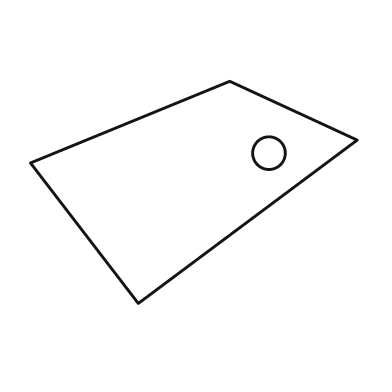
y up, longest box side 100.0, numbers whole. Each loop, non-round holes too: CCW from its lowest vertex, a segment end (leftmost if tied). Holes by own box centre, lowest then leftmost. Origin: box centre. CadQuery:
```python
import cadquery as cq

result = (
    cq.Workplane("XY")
    .moveTo(-17.0, -34.0)
    .lineTo(50.0, 16.0)
    .lineTo(11.0, 34.0)
    .lineTo(-50.0, 9.0)
    .close()
    .moveTo(23.0, 12.0)
    .circle(5.0)
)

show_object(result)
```